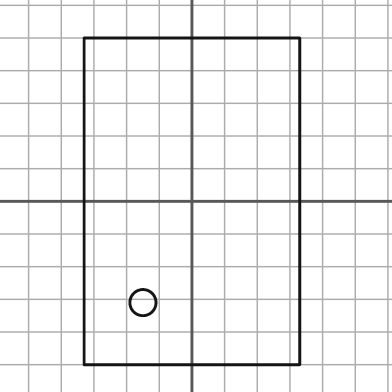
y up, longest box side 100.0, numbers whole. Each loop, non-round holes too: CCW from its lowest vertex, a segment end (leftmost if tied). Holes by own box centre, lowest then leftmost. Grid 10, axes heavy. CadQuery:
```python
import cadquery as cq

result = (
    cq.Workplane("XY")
    .moveTo(-33.0, -50.0)
    .lineTo(33.0, -50.0)
    .lineTo(33.0, 50.0)
    .lineTo(-33.0, 50.0)
    .close()
    .moveTo(-15.0, -31.0)
    .circle(4.0)
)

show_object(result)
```